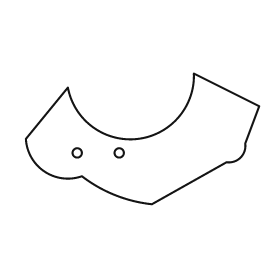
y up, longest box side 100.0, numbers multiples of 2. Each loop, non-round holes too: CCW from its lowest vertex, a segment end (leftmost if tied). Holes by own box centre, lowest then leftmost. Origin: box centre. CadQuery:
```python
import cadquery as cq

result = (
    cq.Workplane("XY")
    .moveTo(4.0, -28.0)
    .lineTo(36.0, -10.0)
    .threePointArc((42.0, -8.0), (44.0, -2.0))
    .lineTo(50.0, 14.0)
    .lineTo(22.0, 28.0)
    .threePointArc((-2.0, 0.0), (-32.0, 22.0))
    .lineTo(-50.0, 0.0)
    .threePointArc((-42.0, -14.0), (-26.0, -16.0))
    .threePointArc((-12.0, -24.0), (4.0, -28.0))
    .close()
    .moveTo(-28.0, -6.0)
    .circle(2.0)
    .moveTo(-10.0, -6.0)
    .circle(2.0)
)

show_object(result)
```